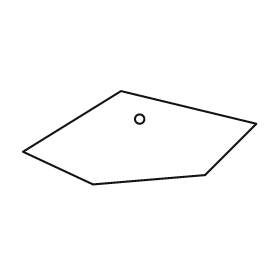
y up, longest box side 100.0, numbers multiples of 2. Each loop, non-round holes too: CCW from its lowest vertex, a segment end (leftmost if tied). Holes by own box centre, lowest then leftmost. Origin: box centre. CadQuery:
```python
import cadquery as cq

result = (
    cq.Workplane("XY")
    .moveTo(-20.0, -20.0)
    .lineTo(28.0, -16.0)
    .lineTo(50.0, 6.0)
    .lineTo(-8.0, 20.0)
    .lineTo(-50.0, -6.0)
    .close()
    .moveTo(0.0, 8.0)
    .circle(2.0)
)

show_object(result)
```